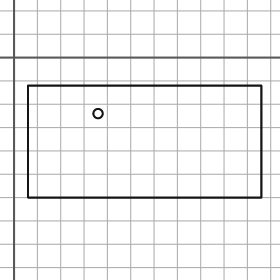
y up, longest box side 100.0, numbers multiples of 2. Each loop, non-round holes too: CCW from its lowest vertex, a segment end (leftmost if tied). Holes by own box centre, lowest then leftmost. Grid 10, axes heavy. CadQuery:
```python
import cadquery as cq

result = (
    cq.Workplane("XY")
    .moveTo(6.0, -60.0)
    .lineTo(106.0, -60.0)
    .lineTo(106.0, -12.0)
    .lineTo(6.0, -12.0)
    .close()
    .moveTo(36.0, -24.0)
    .circle(2.0)
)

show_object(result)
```